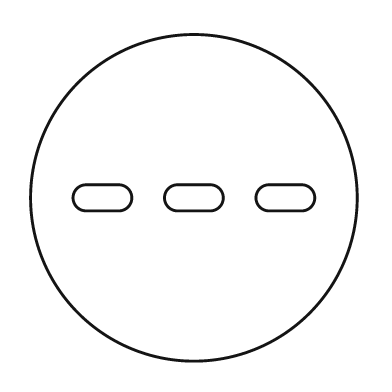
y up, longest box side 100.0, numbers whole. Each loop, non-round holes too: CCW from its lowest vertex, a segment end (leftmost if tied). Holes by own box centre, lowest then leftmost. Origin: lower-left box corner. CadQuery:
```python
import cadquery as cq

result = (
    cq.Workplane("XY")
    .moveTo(50.0, 50.0)
    .circle(50.0)
    .moveTo(17.0, 46.0)
    .lineTo(27.0, 46.0)
    .threePointArc((31.0, 50.0), (27.0, 54.0))
    .lineTo(17.0, 54.0)
    .threePointArc((13.0, 50.0), (17.0, 46.0))
    .close()
    .moveTo(45.0, 46.0)
    .lineTo(55.0, 46.0)
    .threePointArc((59.0, 50.0), (55.0, 54.0))
    .lineTo(45.0, 54.0)
    .threePointArc((41.0, 50.0), (45.0, 46.0))
    .close()
    .moveTo(73.0, 46.0)
    .lineTo(83.0, 46.0)
    .threePointArc((87.0, 50.0), (83.0, 54.0))
    .lineTo(73.0, 54.0)
    .threePointArc((69.0, 50.0), (73.0, 46.0))
    .close()
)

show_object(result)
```